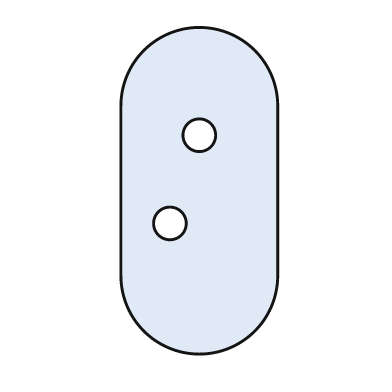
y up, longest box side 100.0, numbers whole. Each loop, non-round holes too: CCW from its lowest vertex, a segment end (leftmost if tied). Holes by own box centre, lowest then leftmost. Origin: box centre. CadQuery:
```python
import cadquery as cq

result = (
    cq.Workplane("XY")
    .moveTo(-24.0, -26.0)
    .threePointArc((0.0, -50.0), (24.0, -26.0))
    .lineTo(24.0, 26.0)
    .threePointArc((0.0, 50.0), (-24.0, 26.0))
    .close()
    .moveTo(-9.0, -10.0)
    .circle(5.0)
    .moveTo(0.0, 17.0)
    .circle(5.0)
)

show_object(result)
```